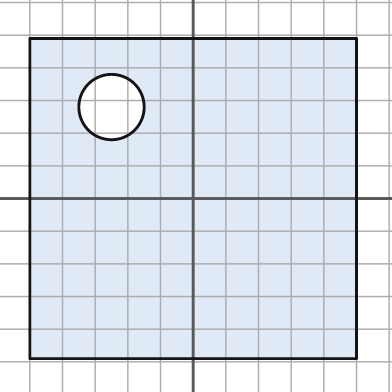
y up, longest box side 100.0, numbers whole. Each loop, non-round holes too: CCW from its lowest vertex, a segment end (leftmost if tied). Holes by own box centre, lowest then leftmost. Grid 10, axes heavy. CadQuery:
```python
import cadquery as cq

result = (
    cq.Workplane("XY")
    .moveTo(-50.0, -49.0)
    .lineTo(50.0, -49.0)
    .lineTo(50.0, 49.0)
    .lineTo(-50.0, 49.0)
    .close()
    .moveTo(-25.0, 28.0)
    .circle(10.0)
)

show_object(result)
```